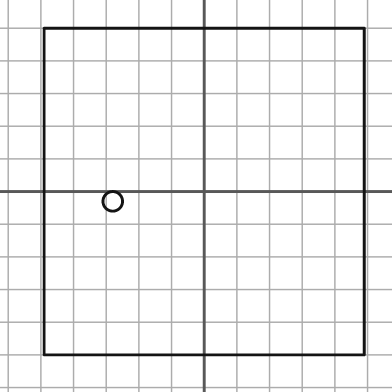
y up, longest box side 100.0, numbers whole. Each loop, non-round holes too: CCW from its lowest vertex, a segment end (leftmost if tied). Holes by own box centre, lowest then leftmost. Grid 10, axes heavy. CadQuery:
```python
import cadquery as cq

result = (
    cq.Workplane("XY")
    .moveTo(-49.0, -50.0)
    .lineTo(49.0, -50.0)
    .lineTo(49.0, 50.0)
    .lineTo(-49.0, 50.0)
    .close()
    .moveTo(-28.0, -3.0)
    .circle(3.0)
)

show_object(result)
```